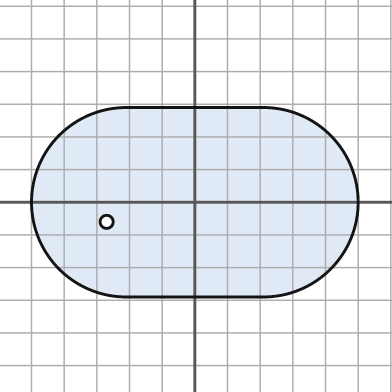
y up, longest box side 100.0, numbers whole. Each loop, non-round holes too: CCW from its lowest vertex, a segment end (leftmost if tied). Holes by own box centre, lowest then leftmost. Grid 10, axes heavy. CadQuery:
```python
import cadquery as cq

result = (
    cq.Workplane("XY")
    .moveTo(-21.0, -29.0)
    .lineTo(21.0, -29.0)
    .threePointArc((50.0, 0.0), (21.0, 29.0))
    .lineTo(-21.0, 29.0)
    .threePointArc((-50.0, 0.0), (-21.0, -29.0))
    .close()
    .moveTo(-27.0, -6.0)
    .circle(2.0)
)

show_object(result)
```